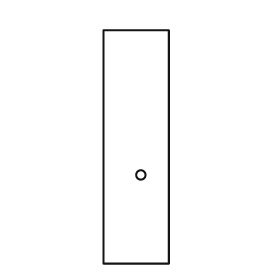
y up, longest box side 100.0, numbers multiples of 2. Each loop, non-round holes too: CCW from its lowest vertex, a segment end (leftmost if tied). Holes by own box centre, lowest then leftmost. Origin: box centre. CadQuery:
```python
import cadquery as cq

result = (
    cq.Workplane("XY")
    .moveTo(-14.0, -50.0)
    .lineTo(14.0, -50.0)
    .lineTo(14.0, 50.0)
    .lineTo(-14.0, 50.0)
    .close()
    .moveTo(2.0, -12.0)
    .circle(2.0)
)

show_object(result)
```